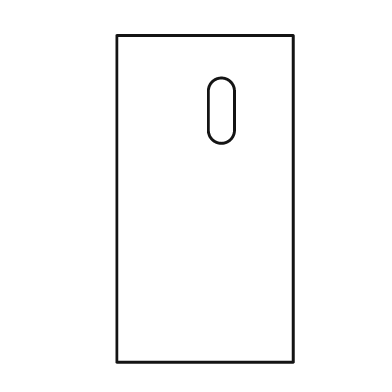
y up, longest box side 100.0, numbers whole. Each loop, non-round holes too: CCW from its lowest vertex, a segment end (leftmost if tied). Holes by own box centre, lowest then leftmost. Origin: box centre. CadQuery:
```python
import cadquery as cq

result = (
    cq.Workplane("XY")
    .moveTo(-27.0, -50.0)
    .lineTo(27.0, -50.0)
    .lineTo(27.0, 50.0)
    .lineTo(-27.0, 50.0)
    .close()
    .moveTo(1.0, 21.0)
    .threePointArc((5.0, 17.0), (9.0, 21.0))
    .lineTo(9.0, 33.0)
    .threePointArc((5.0, 37.0), (1.0, 33.0))
    .close()
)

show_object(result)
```